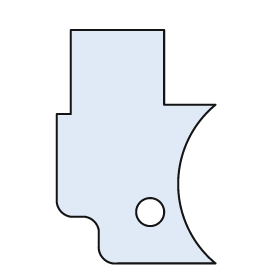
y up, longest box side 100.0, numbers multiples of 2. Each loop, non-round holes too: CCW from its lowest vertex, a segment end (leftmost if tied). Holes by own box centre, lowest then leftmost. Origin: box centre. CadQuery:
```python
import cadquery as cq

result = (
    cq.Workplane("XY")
    .moveTo(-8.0, -50.0)
    .lineTo(34.0, -50.0)
    .threePointArc((18.0, -16.0), (34.0, 18.0))
    .lineTo(12.0, 18.0)
    .lineTo(12.0, 50.0)
    .lineTo(-28.0, 50.0)
    .lineTo(-28.0, 14.0)
    .lineTo(-34.0, 14.0)
    .lineTo(-34.0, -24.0)
    .threePointArc((-32.0, -28.0), (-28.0, -30.0))
    .lineTo(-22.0, -30.0)
    .threePointArc((-18.0, -32.0), (-16.0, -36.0))
    .lineTo(-16.0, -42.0)
    .threePointArc((-14.0, -48.0), (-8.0, -50.0))
    .close()
    .moveTo(6.0, -28.0)
    .circle(6.0)
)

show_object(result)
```